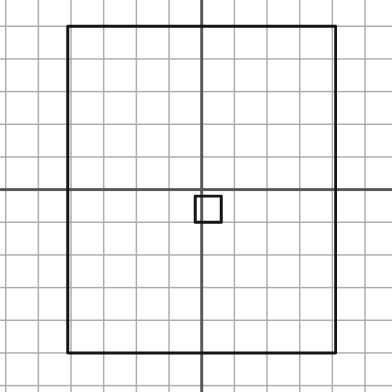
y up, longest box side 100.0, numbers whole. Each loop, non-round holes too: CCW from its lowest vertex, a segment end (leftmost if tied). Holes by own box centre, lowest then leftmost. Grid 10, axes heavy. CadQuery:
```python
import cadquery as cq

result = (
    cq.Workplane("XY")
    .moveTo(-41.0, -50.0)
    .lineTo(41.0, -50.0)
    .lineTo(41.0, 50.0)
    .lineTo(-41.0, 50.0)
    .close()
    .moveTo(-2.0, -10.0)
    .lineTo(6.0, -10.0)
    .lineTo(6.0, -2.0)
    .lineTo(-2.0, -2.0)
    .close()
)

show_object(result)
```